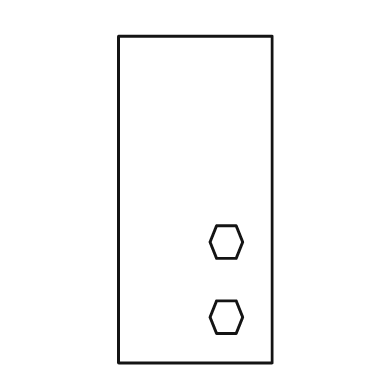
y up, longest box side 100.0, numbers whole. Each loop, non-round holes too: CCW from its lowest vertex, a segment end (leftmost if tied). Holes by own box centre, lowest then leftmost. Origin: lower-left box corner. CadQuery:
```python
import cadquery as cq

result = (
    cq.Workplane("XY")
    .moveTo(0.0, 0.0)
    .lineTo(47.0, 0.0)
    .lineTo(47.0, 100.0)
    .lineTo(0.0, 100.0)
    .close()
    .moveTo(30.0, 9.0)
    .lineTo(36.0, 9.0)
    .lineTo(38.0, 14.0)
    .lineTo(36.0, 19.0)
    .lineTo(30.0, 19.0)
    .lineTo(28.0, 14.0)
    .close()
    .moveTo(30.0, 32.0)
    .lineTo(36.0, 32.0)
    .lineTo(38.0, 37.0)
    .lineTo(36.0, 42.0)
    .lineTo(30.0, 42.0)
    .lineTo(28.0, 37.0)
    .close()
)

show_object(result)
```